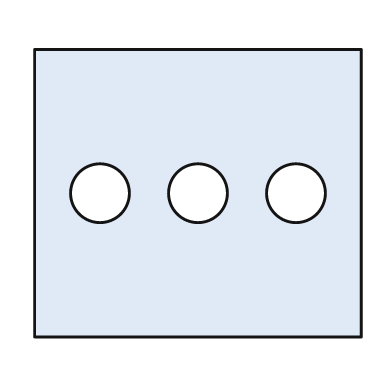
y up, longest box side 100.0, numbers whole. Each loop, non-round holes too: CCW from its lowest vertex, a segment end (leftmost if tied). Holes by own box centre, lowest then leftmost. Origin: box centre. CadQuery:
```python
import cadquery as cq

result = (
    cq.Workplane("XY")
    .moveTo(-50.0, -44.0)
    .lineTo(50.0, -44.0)
    .lineTo(50.0, 44.0)
    .lineTo(-50.0, 44.0)
    .close()
    .moveTo(-30.0, 0.0)
    .circle(9.0)
    .moveTo(0.0, 0.0)
    .circle(9.0)
    .moveTo(30.0, 0.0)
    .circle(9.0)
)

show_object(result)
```